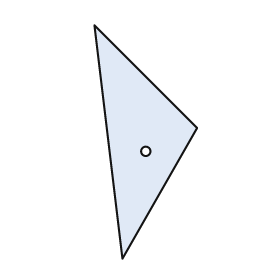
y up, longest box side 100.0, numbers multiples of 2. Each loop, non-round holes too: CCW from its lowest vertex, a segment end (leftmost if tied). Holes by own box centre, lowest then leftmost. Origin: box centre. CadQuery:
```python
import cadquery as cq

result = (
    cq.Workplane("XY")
    .moveTo(-10.0, -50.0)
    .lineTo(22.0, 6.0)
    .lineTo(-22.0, 50.0)
    .close()
    .moveTo(0.0, -4.0)
    .circle(2.0)
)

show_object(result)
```